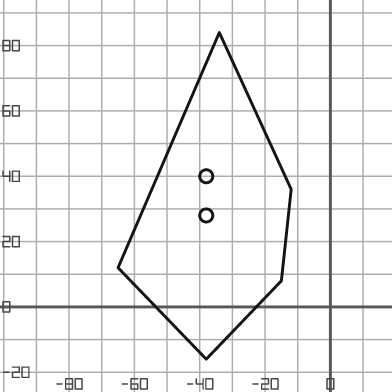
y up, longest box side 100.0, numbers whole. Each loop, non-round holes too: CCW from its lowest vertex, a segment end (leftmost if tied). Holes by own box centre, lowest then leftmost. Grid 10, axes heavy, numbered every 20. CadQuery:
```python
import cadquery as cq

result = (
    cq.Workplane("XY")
    .moveTo(-38.0, -16.0)
    .lineTo(-15.0, 8.0)
    .lineTo(-12.0, 36.0)
    .lineTo(-34.0, 84.0)
    .lineTo(-65.0, 12.0)
    .close()
    .moveTo(-38.0, 28.0)
    .circle(2.0)
    .moveTo(-38.0, 40.0)
    .circle(2.0)
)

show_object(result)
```